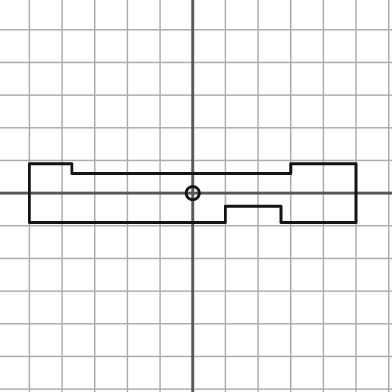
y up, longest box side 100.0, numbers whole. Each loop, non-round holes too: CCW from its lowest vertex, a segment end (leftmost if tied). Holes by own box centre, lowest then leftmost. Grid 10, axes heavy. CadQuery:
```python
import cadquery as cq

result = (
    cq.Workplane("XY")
    .moveTo(-50.0, -9.0)
    .lineTo(10.0, -9.0)
    .lineTo(10.0, -4.0)
    .lineTo(27.0, -4.0)
    .lineTo(27.0, -9.0)
    .lineTo(50.0, -9.0)
    .lineTo(50.0, 9.0)
    .lineTo(30.0, 9.0)
    .lineTo(30.0, 6.0)
    .lineTo(-37.0, 6.0)
    .lineTo(-37.0, 9.0)
    .lineTo(-50.0, 9.0)
    .close()
    .moveTo(0.0, 0.0)
    .circle(2.0)
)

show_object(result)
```